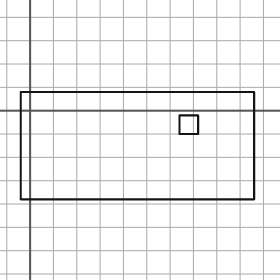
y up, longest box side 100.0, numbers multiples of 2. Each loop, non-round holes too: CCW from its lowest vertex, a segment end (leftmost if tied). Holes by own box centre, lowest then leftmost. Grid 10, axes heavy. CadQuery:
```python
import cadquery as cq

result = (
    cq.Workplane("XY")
    .moveTo(-4.0, -38.0)
    .lineTo(96.0, -38.0)
    .lineTo(96.0, 8.0)
    .lineTo(-4.0, 8.0)
    .close()
    .moveTo(64.0, -10.0)
    .lineTo(72.0, -10.0)
    .lineTo(72.0, -2.0)
    .lineTo(64.0, -2.0)
    .close()
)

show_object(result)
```